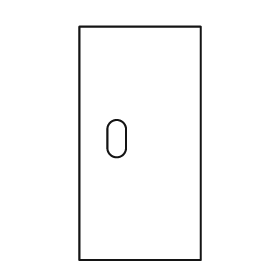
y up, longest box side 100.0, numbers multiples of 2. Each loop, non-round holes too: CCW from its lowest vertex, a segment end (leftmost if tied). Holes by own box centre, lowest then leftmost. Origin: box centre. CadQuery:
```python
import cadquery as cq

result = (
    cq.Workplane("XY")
    .moveTo(-26.0, -50.0)
    .lineTo(26.0, -50.0)
    .lineTo(26.0, 50.0)
    .lineTo(-26.0, 50.0)
    .close()
    .moveTo(-14.0, -2.0)
    .threePointArc((-10.0, -6.0), (-6.0, -2.0))
    .lineTo(-6.0, 6.0)
    .threePointArc((-10.0, 10.0), (-14.0, 6.0))
    .close()
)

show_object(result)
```